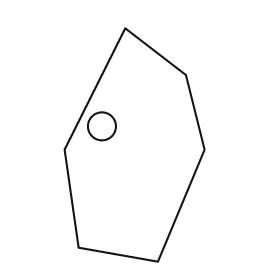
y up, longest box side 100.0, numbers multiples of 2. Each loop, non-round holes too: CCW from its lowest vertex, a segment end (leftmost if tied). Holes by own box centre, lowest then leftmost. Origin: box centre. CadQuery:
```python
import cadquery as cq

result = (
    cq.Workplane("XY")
    .moveTo(10.0, -50.0)
    .lineTo(30.0, -2.0)
    .lineTo(22.0, 30.0)
    .lineTo(-4.0, 50.0)
    .lineTo(-30.0, -2.0)
    .lineTo(-24.0, -44.0)
    .close()
    .moveTo(-14.0, 8.0)
    .circle(6.0)
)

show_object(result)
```